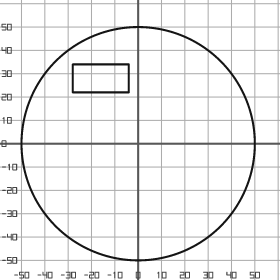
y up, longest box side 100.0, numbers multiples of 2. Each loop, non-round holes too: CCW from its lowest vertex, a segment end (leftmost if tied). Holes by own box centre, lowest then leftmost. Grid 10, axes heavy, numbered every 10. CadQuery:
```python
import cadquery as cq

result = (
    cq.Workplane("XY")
    .moveTo(0.0, 0.0)
    .circle(50.0)
    .moveTo(-28.0, 22.0)
    .lineTo(-4.0, 22.0)
    .lineTo(-4.0, 34.0)
    .lineTo(-28.0, 34.0)
    .close()
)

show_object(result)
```